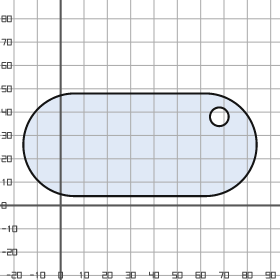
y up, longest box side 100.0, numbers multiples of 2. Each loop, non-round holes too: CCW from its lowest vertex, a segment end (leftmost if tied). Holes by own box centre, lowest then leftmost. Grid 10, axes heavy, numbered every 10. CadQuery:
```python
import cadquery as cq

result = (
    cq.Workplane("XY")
    .moveTo(6.0, 4.0)
    .lineTo(62.0, 4.0)
    .threePointArc((84.0, 26.0), (62.0, 48.0))
    .lineTo(6.0, 48.0)
    .threePointArc((-16.0, 26.0), (6.0, 4.0))
    .close()
    .moveTo(68.0, 38.0)
    .circle(4.0)
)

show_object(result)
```